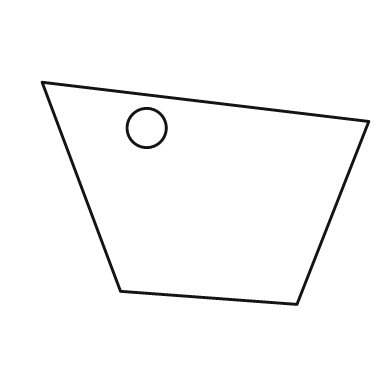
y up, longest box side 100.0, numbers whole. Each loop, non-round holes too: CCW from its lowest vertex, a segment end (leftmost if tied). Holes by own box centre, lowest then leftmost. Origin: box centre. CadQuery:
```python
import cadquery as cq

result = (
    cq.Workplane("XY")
    .moveTo(28.0, -34.0)
    .lineTo(50.0, 22.0)
    .lineTo(-50.0, 34.0)
    .lineTo(-26.0, -30.0)
    .close()
    .moveTo(-18.0, 20.0)
    .circle(6.0)
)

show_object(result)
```